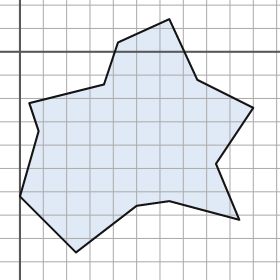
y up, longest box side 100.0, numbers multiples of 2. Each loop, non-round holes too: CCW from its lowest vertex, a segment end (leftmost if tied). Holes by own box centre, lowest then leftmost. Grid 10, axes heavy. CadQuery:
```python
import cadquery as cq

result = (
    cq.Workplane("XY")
    .moveTo(24.0, -86.0)
    .lineTo(50.0, -66.0)
    .lineTo(64.0, -64.0)
    .lineTo(94.0, -72.0)
    .lineTo(84.0, -48.0)
    .lineTo(100.0, -24.0)
    .lineTo(76.0, -12.0)
    .lineTo(64.0, 14.0)
    .lineTo(42.0, 4.0)
    .lineTo(36.0, -14.0)
    .lineTo(4.0, -22.0)
    .lineTo(8.0, -34.0)
    .lineTo(0.0, -62.0)
    .close()
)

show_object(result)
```